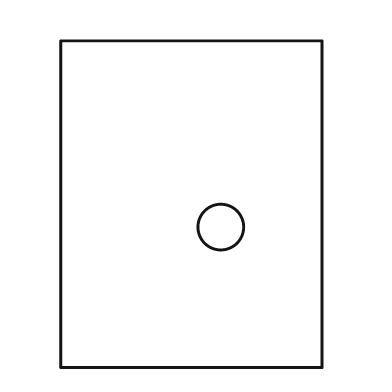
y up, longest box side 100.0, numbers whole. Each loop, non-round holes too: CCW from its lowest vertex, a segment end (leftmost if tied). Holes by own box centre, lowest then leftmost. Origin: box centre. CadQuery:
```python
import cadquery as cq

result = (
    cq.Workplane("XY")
    .moveTo(-40.0, -50.0)
    .lineTo(40.0, -50.0)
    .lineTo(40.0, 50.0)
    .lineTo(-40.0, 50.0)
    .close()
    .moveTo(9.0, -7.0)
    .circle(7.0)
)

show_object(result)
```